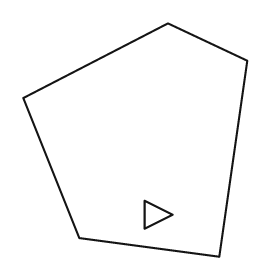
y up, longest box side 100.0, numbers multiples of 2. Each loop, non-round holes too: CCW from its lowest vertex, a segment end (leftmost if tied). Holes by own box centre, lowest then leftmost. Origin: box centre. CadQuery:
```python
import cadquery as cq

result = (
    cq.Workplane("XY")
    .moveTo(36.0, -50.0)
    .lineTo(48.0, 34.0)
    .lineTo(14.0, 50.0)
    .lineTo(-48.0, 18.0)
    .lineTo(-24.0, -42.0)
    .close()
    .moveTo(4.0, -38.0)
    .lineTo(16.0, -32.0)
    .lineTo(4.0, -26.0)
    .close()
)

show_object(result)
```